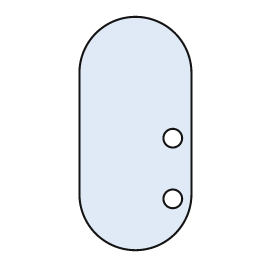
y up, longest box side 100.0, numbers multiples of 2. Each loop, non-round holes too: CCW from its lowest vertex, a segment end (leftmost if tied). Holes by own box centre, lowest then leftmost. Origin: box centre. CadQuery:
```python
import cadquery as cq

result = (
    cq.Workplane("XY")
    .moveTo(-24.0, -26.0)
    .threePointArc((0.0, -50.0), (24.0, -26.0))
    .lineTo(24.0, 26.0)
    .threePointArc((0.0, 50.0), (-24.0, 26.0))
    .close()
    .moveTo(16.0, -28.0)
    .circle(4.0)
    .moveTo(16.0, -2.0)
    .circle(4.0)
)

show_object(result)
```